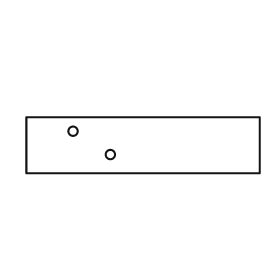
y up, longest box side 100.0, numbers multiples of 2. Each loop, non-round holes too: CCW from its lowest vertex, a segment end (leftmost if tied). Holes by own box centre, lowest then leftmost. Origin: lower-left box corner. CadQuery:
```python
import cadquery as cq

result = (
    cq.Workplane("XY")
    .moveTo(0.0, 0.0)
    .lineTo(100.0, 0.0)
    .lineTo(100.0, 24.0)
    .lineTo(0.0, 24.0)
    .close()
    .moveTo(36.0, 8.0)
    .circle(2.0)
    .moveTo(20.0, 18.0)
    .circle(2.0)
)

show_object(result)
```